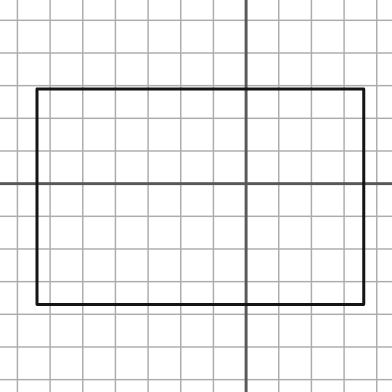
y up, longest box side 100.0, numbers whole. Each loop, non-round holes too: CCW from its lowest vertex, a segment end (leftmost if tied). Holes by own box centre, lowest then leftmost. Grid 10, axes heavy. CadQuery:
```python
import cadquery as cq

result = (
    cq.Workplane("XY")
    .moveTo(-64.0, -37.0)
    .lineTo(36.0, -37.0)
    .lineTo(36.0, 29.0)
    .lineTo(-64.0, 29.0)
    .close()
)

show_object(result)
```